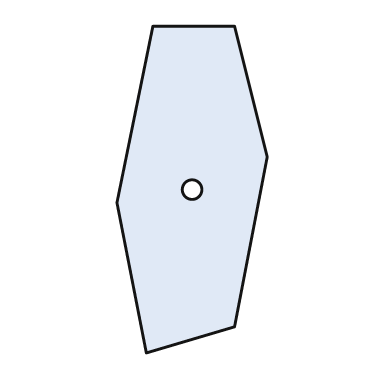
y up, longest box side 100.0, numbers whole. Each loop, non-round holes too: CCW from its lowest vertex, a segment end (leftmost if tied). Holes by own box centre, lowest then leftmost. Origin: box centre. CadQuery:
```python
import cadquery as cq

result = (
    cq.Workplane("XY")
    .moveTo(-14.0, -50.0)
    .lineTo(13.0, -42.0)
    .lineTo(23.0, 10.0)
    .lineTo(13.0, 50.0)
    .lineTo(-12.0, 50.0)
    .lineTo(-23.0, -4.0)
    .close()
    .moveTo(0.0, 0.0)
    .circle(3.0)
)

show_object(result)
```